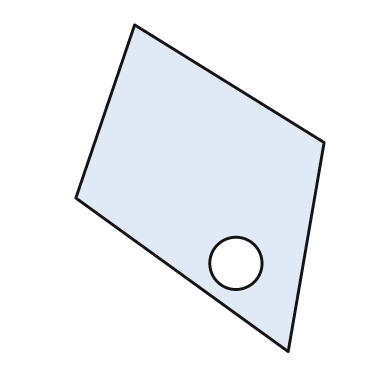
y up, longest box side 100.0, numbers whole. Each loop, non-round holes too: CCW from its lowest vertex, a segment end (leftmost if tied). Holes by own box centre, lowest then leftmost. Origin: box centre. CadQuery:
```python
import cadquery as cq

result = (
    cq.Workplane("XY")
    .moveTo(27.0, -50.0)
    .lineTo(38.0, 14.0)
    .lineTo(-20.0, 50.0)
    .lineTo(-38.0, -3.0)
    .close()
    .moveTo(11.0, -23.0)
    .circle(8.0)
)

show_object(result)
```